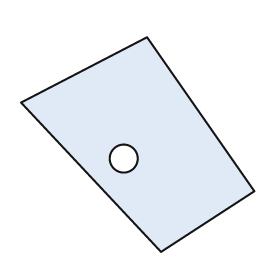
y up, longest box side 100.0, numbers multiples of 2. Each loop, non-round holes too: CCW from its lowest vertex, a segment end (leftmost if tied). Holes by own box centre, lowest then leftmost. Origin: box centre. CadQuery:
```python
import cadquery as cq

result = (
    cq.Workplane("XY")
    .moveTo(10.0, -46.0)
    .lineTo(50.0, -20.0)
    .lineTo(4.0, 46.0)
    .lineTo(-50.0, 18.0)
    .close()
    .moveTo(-6.0, -6.0)
    .circle(6.0)
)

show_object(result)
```